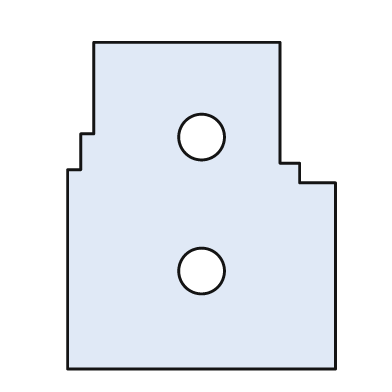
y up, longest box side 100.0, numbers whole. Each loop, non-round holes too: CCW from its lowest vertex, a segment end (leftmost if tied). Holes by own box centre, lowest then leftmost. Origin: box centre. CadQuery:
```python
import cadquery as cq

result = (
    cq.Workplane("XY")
    .moveTo(-41.0, -50.0)
    .lineTo(41.0, -50.0)
    .lineTo(41.0, 7.0)
    .lineTo(30.0, 7.0)
    .lineTo(30.0, 13.0)
    .lineTo(24.0, 13.0)
    .lineTo(24.0, 50.0)
    .lineTo(-33.0, 50.0)
    .lineTo(-33.0, 22.0)
    .lineTo(-37.0, 22.0)
    .lineTo(-37.0, 11.0)
    .lineTo(-41.0, 11.0)
    .close()
    .moveTo(0.0, -20.0)
    .circle(7.0)
    .moveTo(0.0, 21.0)
    .circle(7.0)
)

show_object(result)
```